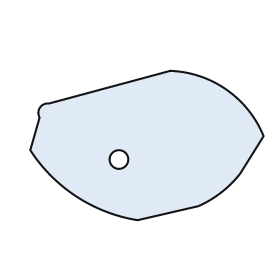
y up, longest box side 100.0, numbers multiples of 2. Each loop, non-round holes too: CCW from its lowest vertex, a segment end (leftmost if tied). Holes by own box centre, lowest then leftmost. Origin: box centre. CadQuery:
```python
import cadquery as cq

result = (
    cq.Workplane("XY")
    .moveTo(-4.0, -32.0)
    .lineTo(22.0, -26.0)
    .threePointArc((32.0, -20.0), (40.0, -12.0))
    .lineTo(50.0, 4.0)
    .threePointArc((34.0, 24.0), (10.0, 32.0))
    .lineTo(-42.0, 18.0)
    .threePointArc((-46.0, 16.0), (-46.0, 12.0))
    .lineTo(-50.0, -2.0)
    .threePointArc((-30.0, -22.0), (-4.0, -32.0))
    .close()
    .moveTo(-12.0, -6.0)
    .circle(4.0)
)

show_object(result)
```